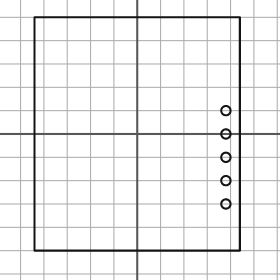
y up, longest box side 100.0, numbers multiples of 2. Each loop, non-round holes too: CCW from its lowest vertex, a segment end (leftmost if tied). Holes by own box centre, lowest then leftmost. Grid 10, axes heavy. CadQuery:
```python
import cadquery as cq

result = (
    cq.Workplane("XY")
    .moveTo(-44.0, -50.0)
    .lineTo(44.0, -50.0)
    .lineTo(44.0, 50.0)
    .lineTo(-44.0, 50.0)
    .close()
    .moveTo(38.0, -30.0)
    .circle(2.0)
    .moveTo(38.0, -20.0)
    .circle(2.0)
    .moveTo(38.0, -10.0)
    .circle(2.0)
    .moveTo(38.0, 0.0)
    .circle(2.0)
    .moveTo(38.0, 10.0)
    .circle(2.0)
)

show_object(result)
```